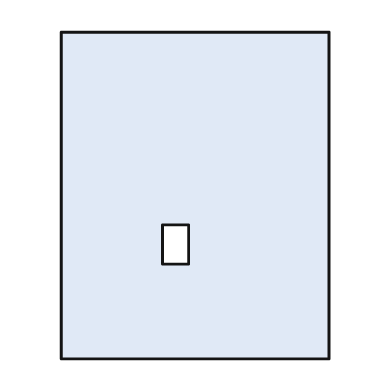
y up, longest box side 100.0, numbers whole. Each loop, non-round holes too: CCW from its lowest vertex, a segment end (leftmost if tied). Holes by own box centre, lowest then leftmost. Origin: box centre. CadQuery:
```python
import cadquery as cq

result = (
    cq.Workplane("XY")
    .moveTo(-41.0, -50.0)
    .lineTo(41.0, -50.0)
    .lineTo(41.0, 50.0)
    .lineTo(-41.0, 50.0)
    .close()
    .moveTo(-10.0, -21.0)
    .lineTo(-2.0, -21.0)
    .lineTo(-2.0, -9.0)
    .lineTo(-10.0, -9.0)
    .close()
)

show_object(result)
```